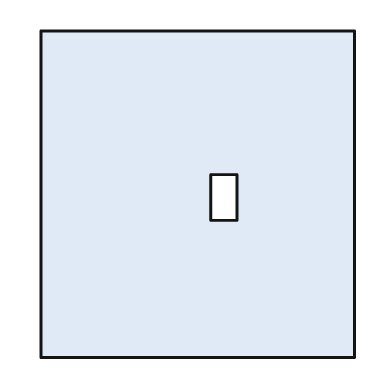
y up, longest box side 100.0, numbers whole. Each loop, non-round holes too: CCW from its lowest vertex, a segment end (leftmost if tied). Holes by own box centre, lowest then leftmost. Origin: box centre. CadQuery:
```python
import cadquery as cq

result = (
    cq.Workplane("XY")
    .moveTo(-48.0, -50.0)
    .lineTo(48.0, -50.0)
    .lineTo(48.0, 50.0)
    .lineTo(-48.0, 50.0)
    .close()
    .moveTo(4.0, -8.0)
    .lineTo(12.0, -8.0)
    .lineTo(12.0, 6.0)
    .lineTo(4.0, 6.0)
    .close()
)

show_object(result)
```